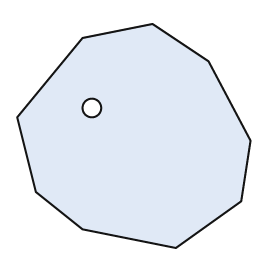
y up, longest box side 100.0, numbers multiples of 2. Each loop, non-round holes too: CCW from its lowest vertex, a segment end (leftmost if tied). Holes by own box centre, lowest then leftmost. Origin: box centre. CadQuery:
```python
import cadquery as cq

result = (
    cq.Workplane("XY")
    .moveTo(18.0, -48.0)
    .lineTo(46.0, -28.0)
    .lineTo(50.0, -2.0)
    .lineTo(32.0, 32.0)
    .lineTo(8.0, 48.0)
    .lineTo(-22.0, 42.0)
    .lineTo(-50.0, 8.0)
    .lineTo(-42.0, -24.0)
    .lineTo(-22.0, -40.0)
    .close()
    .moveTo(-18.0, 12.0)
    .circle(4.0)
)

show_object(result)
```